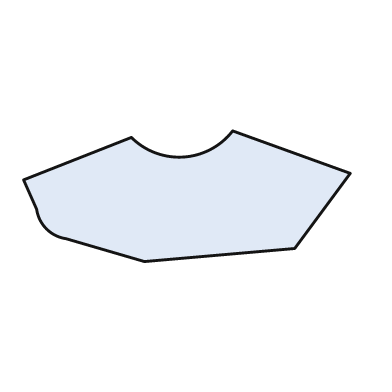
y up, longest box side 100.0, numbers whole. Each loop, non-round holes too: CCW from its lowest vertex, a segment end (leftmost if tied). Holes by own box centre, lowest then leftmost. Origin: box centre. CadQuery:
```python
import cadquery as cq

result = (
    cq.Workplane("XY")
    .moveTo(-13.0, -20.0)
    .lineTo(33.0, -16.0)
    .lineTo(50.0, 7.0)
    .lineTo(14.0, 20.0)
    .threePointArc((-1.0, 12.0), (-17.0, 18.0))
    .lineTo(-50.0, 5.0)
    .lineTo(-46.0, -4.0)
    .threePointArc((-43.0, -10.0), (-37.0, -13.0))
    .close()
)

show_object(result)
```